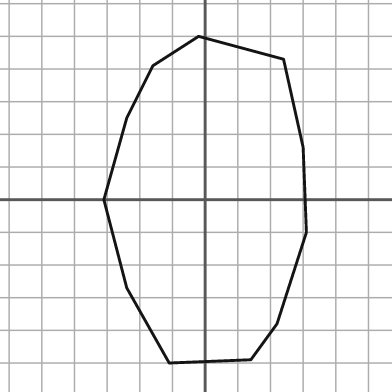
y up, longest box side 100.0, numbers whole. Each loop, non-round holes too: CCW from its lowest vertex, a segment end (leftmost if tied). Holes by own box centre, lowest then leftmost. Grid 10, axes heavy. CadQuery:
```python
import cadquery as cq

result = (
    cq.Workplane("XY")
    .moveTo(-11.0, -50.0)
    .lineTo(14.0, -49.0)
    .lineTo(22.0, -38.0)
    .lineTo(31.0, -10.0)
    .lineTo(30.0, 16.0)
    .lineTo(24.0, 43.0)
    .lineTo(-2.0, 50.0)
    .lineTo(-16.0, 41.0)
    .lineTo(-24.0, 25.0)
    .lineTo(-31.0, 0.0)
    .lineTo(-24.0, -27.0)
    .close()
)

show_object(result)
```